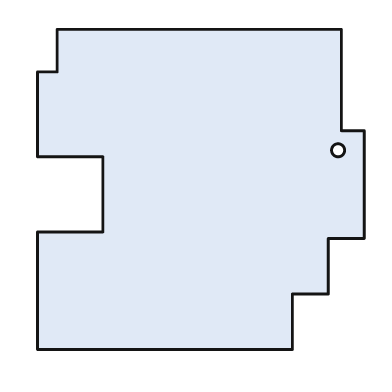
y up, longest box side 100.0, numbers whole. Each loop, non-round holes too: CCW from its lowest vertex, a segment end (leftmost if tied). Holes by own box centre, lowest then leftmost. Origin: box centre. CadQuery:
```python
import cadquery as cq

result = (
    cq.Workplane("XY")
    .moveTo(-50.0, -49.0)
    .lineTo(28.0, -49.0)
    .lineTo(28.0, -32.0)
    .lineTo(39.0, -32.0)
    .lineTo(39.0, -15.0)
    .lineTo(50.0, -15.0)
    .lineTo(50.0, 18.0)
    .lineTo(43.0, 18.0)
    .lineTo(43.0, 49.0)
    .lineTo(-44.0, 49.0)
    .lineTo(-44.0, 36.0)
    .lineTo(-50.0, 36.0)
    .lineTo(-50.0, 10.0)
    .lineTo(-30.0, 10.0)
    .lineTo(-30.0, -13.0)
    .lineTo(-50.0, -13.0)
    .close()
    .moveTo(42.0, 12.0)
    .circle(2.0)
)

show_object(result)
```